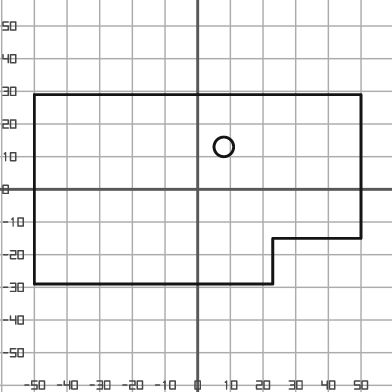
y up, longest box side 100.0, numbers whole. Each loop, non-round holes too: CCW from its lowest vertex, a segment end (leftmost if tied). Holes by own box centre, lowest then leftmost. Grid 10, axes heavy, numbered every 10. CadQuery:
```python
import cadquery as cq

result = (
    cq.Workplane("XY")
    .moveTo(-50.0, -29.0)
    .lineTo(23.0, -29.0)
    .lineTo(23.0, -15.0)
    .lineTo(50.0, -15.0)
    .lineTo(50.0, 29.0)
    .lineTo(-50.0, 29.0)
    .close()
    .moveTo(8.0, 13.0)
    .circle(3.0)
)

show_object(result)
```